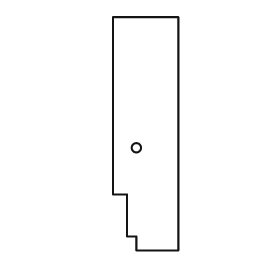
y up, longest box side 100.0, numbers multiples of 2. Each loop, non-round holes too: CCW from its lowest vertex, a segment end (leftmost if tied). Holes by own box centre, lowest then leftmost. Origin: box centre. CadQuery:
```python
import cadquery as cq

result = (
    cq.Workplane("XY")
    .moveTo(-4.0, -50.0)
    .lineTo(14.0, -50.0)
    .lineTo(14.0, 50.0)
    .lineTo(-14.0, 50.0)
    .lineTo(-14.0, -26.0)
    .lineTo(-8.0, -26.0)
    .lineTo(-8.0, -44.0)
    .lineTo(-4.0, -44.0)
    .close()
    .moveTo(-4.0, -6.0)
    .circle(2.0)
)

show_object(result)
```